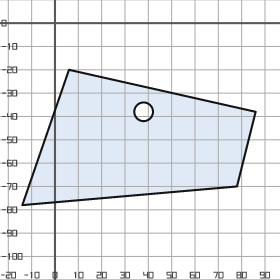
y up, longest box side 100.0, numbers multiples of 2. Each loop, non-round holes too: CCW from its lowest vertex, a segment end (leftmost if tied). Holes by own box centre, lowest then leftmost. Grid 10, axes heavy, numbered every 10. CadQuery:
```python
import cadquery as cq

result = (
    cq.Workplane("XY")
    .moveTo(-14.0, -78.0)
    .lineTo(78.0, -70.0)
    .lineTo(86.0, -38.0)
    .lineTo(6.0, -20.0)
    .close()
    .moveTo(38.0, -38.0)
    .circle(4.0)
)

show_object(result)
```